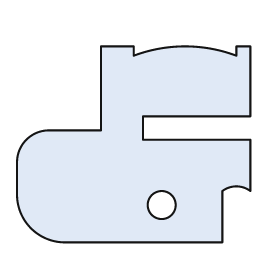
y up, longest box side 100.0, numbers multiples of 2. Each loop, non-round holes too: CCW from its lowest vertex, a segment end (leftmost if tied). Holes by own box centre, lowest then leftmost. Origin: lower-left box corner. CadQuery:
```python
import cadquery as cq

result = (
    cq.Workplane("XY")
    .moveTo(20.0, 0.0)
    .lineTo(88.0, 0.0)
    .lineTo(88.0, 22.0)
    .threePointArc((94.0, 24.0), (100.0, 22.0))
    .lineTo(100.0, 44.0)
    .lineTo(54.0, 44.0)
    .lineTo(54.0, 54.0)
    .lineTo(100.0, 54.0)
    .lineTo(100.0, 84.0)
    .lineTo(94.0, 84.0)
    .lineTo(94.0, 80.0)
    .threePointArc((72.0, 84.0), (50.0, 80.0))
    .lineTo(50.0, 84.0)
    .lineTo(36.0, 84.0)
    .lineTo(36.0, 48.0)
    .lineTo(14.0, 48.0)
    .threePointArc((4.0, 44.0), (0.0, 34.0))
    .lineTo(0.0, 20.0)
    .threePointArc((6.0, 6.0), (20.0, 0.0))
    .close()
    .moveTo(62.0, 16.0)
    .circle(6.0)
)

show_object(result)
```